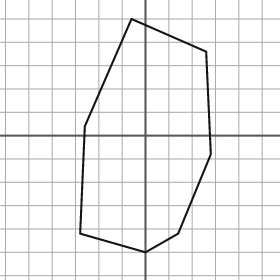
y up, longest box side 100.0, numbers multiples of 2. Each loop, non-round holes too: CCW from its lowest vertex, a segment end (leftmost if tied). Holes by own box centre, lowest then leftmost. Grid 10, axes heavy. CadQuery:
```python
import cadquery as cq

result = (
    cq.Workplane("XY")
    .moveTo(0.0, -50.0)
    .lineTo(14.0, -42.0)
    .lineTo(28.0, -8.0)
    .lineTo(26.0, 36.0)
    .lineTo(-6.0, 50.0)
    .lineTo(-26.0, 4.0)
    .lineTo(-28.0, -42.0)
    .close()
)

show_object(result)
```